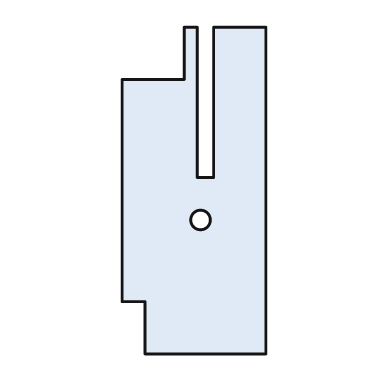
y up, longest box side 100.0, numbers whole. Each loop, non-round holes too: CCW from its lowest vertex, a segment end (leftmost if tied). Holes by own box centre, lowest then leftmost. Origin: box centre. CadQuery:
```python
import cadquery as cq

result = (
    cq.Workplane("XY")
    .moveTo(-15.0, -50.0)
    .lineTo(22.0, -50.0)
    .lineTo(22.0, 50.0)
    .lineTo(6.0, 50.0)
    .lineTo(6.0, 4.0)
    .lineTo(1.0, 4.0)
    .lineTo(1.0, 50.0)
    .lineTo(-3.0, 50.0)
    .lineTo(-3.0, 34.0)
    .lineTo(-22.0, 34.0)
    .lineTo(-22.0, -34.0)
    .lineTo(-15.0, -34.0)
    .close()
    .moveTo(2.0, -9.0)
    .circle(3.0)
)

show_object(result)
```